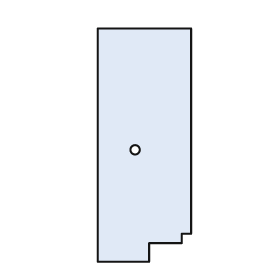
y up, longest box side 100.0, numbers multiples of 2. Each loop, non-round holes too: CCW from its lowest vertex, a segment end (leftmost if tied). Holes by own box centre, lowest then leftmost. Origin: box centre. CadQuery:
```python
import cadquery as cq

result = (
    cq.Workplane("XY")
    .moveTo(-20.0, -50.0)
    .lineTo(2.0, -50.0)
    .lineTo(2.0, -42.0)
    .lineTo(16.0, -42.0)
    .lineTo(16.0, -38.0)
    .lineTo(20.0, -38.0)
    .lineTo(20.0, 50.0)
    .lineTo(-20.0, 50.0)
    .close()
    .moveTo(-4.0, -2.0)
    .circle(2.0)
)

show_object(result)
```